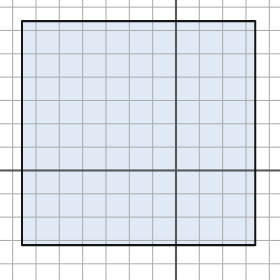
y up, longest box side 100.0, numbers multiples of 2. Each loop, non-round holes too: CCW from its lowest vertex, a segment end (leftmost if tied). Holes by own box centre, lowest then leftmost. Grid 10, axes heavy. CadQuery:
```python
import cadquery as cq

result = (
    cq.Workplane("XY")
    .moveTo(-66.0, -32.0)
    .lineTo(34.0, -32.0)
    .lineTo(34.0, 64.0)
    .lineTo(-66.0, 64.0)
    .close()
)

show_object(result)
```